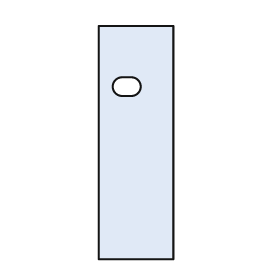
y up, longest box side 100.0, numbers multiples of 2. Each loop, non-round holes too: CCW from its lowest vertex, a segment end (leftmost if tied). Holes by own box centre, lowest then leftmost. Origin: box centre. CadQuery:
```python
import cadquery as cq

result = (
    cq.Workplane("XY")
    .moveTo(-16.0, -50.0)
    .lineTo(16.0, -50.0)
    .lineTo(16.0, 50.0)
    .lineTo(-16.0, 50.0)
    .close()
    .moveTo(-6.0, 20.0)
    .lineTo(-2.0, 20.0)
    .threePointArc((2.0, 24.0), (-2.0, 28.0))
    .lineTo(-6.0, 28.0)
    .threePointArc((-10.0, 24.0), (-6.0, 20.0))
    .close()
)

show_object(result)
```